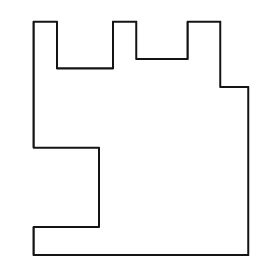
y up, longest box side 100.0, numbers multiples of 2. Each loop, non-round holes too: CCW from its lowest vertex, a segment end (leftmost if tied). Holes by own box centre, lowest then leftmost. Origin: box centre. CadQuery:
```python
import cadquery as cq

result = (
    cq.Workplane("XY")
    .moveTo(-46.0, -50.0)
    .lineTo(46.0, -50.0)
    .lineTo(46.0, 22.0)
    .lineTo(34.0, 22.0)
    .lineTo(34.0, 50.0)
    .lineTo(20.0, 50.0)
    .lineTo(20.0, 34.0)
    .lineTo(-2.0, 34.0)
    .lineTo(-2.0, 50.0)
    .lineTo(-12.0, 50.0)
    .lineTo(-12.0, 30.0)
    .lineTo(-36.0, 30.0)
    .lineTo(-36.0, 50.0)
    .lineTo(-46.0, 50.0)
    .lineTo(-46.0, -4.0)
    .lineTo(-18.0, -4.0)
    .lineTo(-18.0, -38.0)
    .lineTo(-46.0, -38.0)
    .close()
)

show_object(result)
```